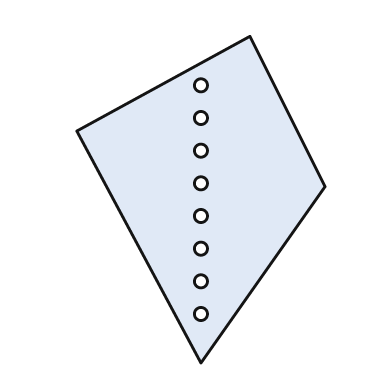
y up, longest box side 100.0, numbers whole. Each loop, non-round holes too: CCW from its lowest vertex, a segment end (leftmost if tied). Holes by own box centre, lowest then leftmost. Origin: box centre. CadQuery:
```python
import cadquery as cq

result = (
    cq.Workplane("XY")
    .moveTo(0.0, -50.0)
    .lineTo(38.0, 4.0)
    .lineTo(15.0, 50.0)
    .lineTo(-38.0, 21.0)
    .close()
    .moveTo(0.0, -35.0)
    .circle(2.0)
    .moveTo(0.0, -25.0)
    .circle(2.0)
    .moveTo(0.0, -15.0)
    .circle(2.0)
    .moveTo(0.0, -5.0)
    .circle(2.0)
    .moveTo(0.0, 5.0)
    .circle(2.0)
    .moveTo(0.0, 15.0)
    .circle(2.0)
    .moveTo(0.0, 25.0)
    .circle(2.0)
    .moveTo(0.0, 35.0)
    .circle(2.0)
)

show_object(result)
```